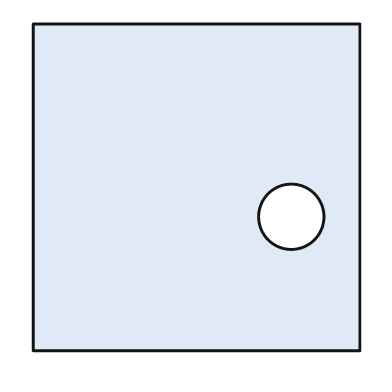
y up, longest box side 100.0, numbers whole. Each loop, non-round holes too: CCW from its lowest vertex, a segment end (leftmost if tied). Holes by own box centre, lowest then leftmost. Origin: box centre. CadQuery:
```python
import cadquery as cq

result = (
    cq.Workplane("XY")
    .moveTo(-50.0, -50.0)
    .lineTo(50.0, -50.0)
    .lineTo(50.0, 50.0)
    .lineTo(-50.0, 50.0)
    .close()
    .moveTo(29.0, -9.0)
    .circle(10.0)
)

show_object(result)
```